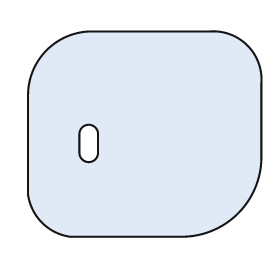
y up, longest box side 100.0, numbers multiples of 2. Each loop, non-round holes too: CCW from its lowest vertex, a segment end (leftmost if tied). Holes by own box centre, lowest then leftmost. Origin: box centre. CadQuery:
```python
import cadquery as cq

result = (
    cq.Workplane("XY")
    .moveTo(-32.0, -44.0)
    .lineTo(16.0, -44.0)
    .threePointArc((40.0, -34.0), (50.0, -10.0))
    .lineTo(50.0, 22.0)
    .threePointArc((44.0, 38.0), (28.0, 44.0))
    .lineTo(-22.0, 44.0)
    .threePointArc((-42.0, 36.0), (-50.0, 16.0))
    .lineTo(-50.0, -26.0)
    .threePointArc((-44.0, -38.0), (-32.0, -44.0))
    .close()
    .moveTo(-28.0, -8.0)
    .threePointArc((-24.0, -12.0), (-20.0, -8.0))
    .lineTo(-20.0, 0.0)
    .threePointArc((-24.0, 4.0), (-28.0, 0.0))
    .close()
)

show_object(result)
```